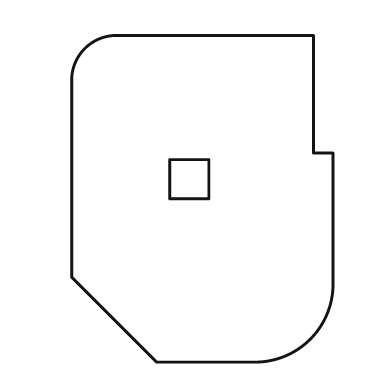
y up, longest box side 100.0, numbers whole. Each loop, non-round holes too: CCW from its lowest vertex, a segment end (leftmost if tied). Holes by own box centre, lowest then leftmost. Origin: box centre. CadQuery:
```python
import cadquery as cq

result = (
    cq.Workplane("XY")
    .moveTo(-14.0, -50.0)
    .lineTo(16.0, -50.0)
    .threePointArc((33.0, -43.0), (40.0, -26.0))
    .lineTo(40.0, 14.0)
    .lineTo(34.0, 14.0)
    .lineTo(34.0, 50.0)
    .lineTo(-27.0, 50.0)
    .threePointArc((-36.0, 46.0), (-40.0, 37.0))
    .lineTo(-40.0, -24.0)
    .close()
    .moveTo(-10.0, 0.0)
    .lineTo(2.0, 0.0)
    .lineTo(2.0, 12.0)
    .lineTo(-10.0, 12.0)
    .close()
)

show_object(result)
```